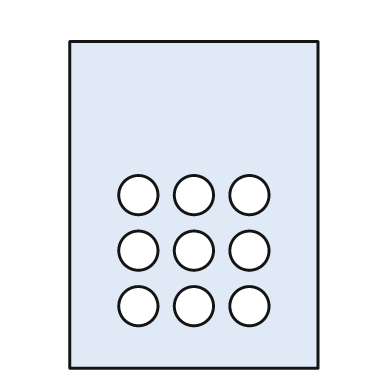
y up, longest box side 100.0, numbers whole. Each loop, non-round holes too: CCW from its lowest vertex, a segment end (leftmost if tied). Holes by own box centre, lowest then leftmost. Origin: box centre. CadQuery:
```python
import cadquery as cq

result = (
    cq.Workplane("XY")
    .moveTo(-38.0, -50.0)
    .lineTo(38.0, -50.0)
    .lineTo(38.0, 50.0)
    .lineTo(-38.0, 50.0)
    .close()
    .moveTo(-17.0, -31.0)
    .circle(6.0)
    .moveTo(0.0, -31.0)
    .circle(6.0)
    .moveTo(17.0, -31.0)
    .circle(6.0)
    .moveTo(-17.0, -14.0)
    .circle(6.0)
    .moveTo(0.0, -14.0)
    .circle(6.0)
    .moveTo(17.0, -14.0)
    .circle(6.0)
    .moveTo(-17.0, 3.0)
    .circle(6.0)
    .moveTo(0.0, 3.0)
    .circle(6.0)
    .moveTo(17.0, 3.0)
    .circle(6.0)
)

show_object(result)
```